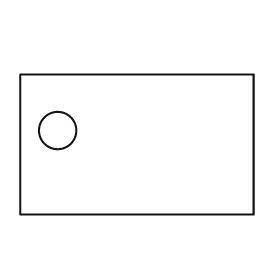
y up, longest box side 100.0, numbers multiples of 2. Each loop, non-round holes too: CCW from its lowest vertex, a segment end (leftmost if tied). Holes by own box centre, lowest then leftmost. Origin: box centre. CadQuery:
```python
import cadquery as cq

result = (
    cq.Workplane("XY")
    .moveTo(-50.0, -30.0)
    .lineTo(50.0, -30.0)
    .lineTo(50.0, 30.0)
    .lineTo(-50.0, 30.0)
    .close()
    .moveTo(-34.0, 6.0)
    .circle(8.0)
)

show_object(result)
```